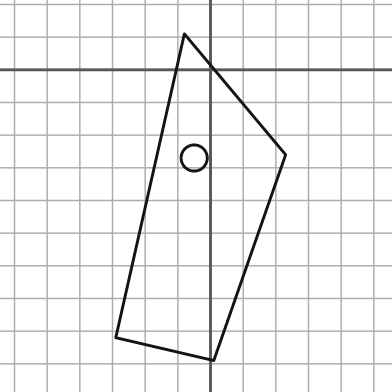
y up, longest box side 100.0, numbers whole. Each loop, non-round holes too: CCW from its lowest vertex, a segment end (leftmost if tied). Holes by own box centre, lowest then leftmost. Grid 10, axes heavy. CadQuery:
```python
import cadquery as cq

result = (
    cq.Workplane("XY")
    .moveTo(1.0, -89.0)
    .lineTo(23.0, -26.0)
    .lineTo(-8.0, 11.0)
    .lineTo(-29.0, -82.0)
    .close()
    .moveTo(-5.0, -27.0)
    .circle(4.0)
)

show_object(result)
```